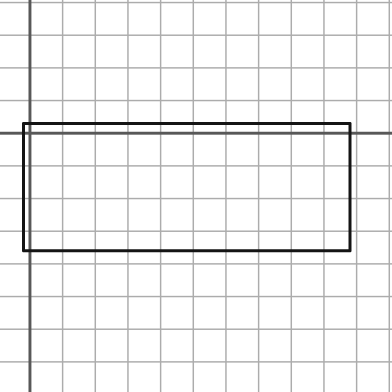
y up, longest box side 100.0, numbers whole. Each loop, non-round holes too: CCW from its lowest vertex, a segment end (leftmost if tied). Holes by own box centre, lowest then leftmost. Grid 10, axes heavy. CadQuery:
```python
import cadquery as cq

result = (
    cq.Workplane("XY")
    .moveTo(-2.0, -36.0)
    .lineTo(98.0, -36.0)
    .lineTo(98.0, 3.0)
    .lineTo(-2.0, 3.0)
    .close()
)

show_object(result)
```